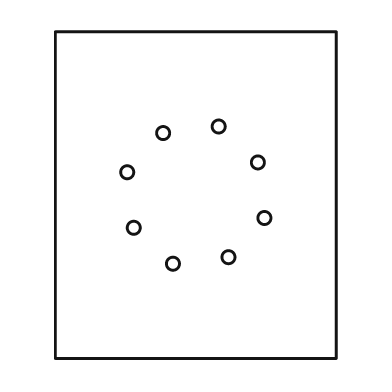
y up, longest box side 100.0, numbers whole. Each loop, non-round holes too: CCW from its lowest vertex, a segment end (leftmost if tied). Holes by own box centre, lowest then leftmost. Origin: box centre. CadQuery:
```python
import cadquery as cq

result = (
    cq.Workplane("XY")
    .moveTo(-43.0, -50.0)
    .lineTo(43.0, -50.0)
    .lineTo(43.0, 50.0)
    .lineTo(-43.0, 50.0)
    .close()
    .moveTo(-7.0, -21.0)
    .circle(2.0)
    .moveTo(10.0, -19.0)
    .circle(2.0)
    .moveTo(-19.0, -10.0)
    .circle(2.0)
    .moveTo(21.0, -7.0)
    .circle(2.0)
    .moveTo(-21.0, 7.0)
    .circle(2.0)
    .moveTo(19.0, 10.0)
    .circle(2.0)
    .moveTo(-10.0, 19.0)
    .circle(2.0)
    .moveTo(7.0, 21.0)
    .circle(2.0)
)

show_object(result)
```